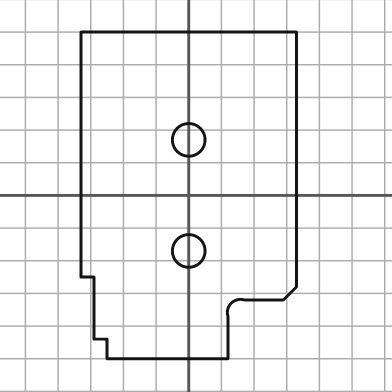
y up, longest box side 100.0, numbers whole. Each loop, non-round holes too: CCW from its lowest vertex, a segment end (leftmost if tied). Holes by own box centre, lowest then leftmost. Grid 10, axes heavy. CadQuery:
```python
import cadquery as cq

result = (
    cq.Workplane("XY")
    .moveTo(-25.0, -50.0)
    .lineTo(12.0, -50.0)
    .lineTo(12.0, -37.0)
    .threePointArc((13.0, -33.0), (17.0, -32.0))
    .lineTo(29.0, -32.0)
    .lineTo(33.0, -28.0)
    .lineTo(33.0, 50.0)
    .lineTo(-33.0, 50.0)
    .lineTo(-33.0, -25.0)
    .lineTo(-29.0, -25.0)
    .lineTo(-29.0, -44.0)
    .lineTo(-25.0, -44.0)
    .close()
    .moveTo(0.0, -17.0)
    .circle(5.0)
    .moveTo(0.0, 17.0)
    .circle(5.0)
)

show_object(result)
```